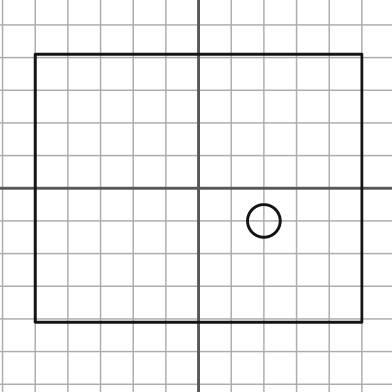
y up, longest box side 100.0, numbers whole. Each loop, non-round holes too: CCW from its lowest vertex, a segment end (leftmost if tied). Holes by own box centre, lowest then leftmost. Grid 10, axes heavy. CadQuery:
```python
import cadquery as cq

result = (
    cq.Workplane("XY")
    .moveTo(-50.0, -41.0)
    .lineTo(50.0, -41.0)
    .lineTo(50.0, 41.0)
    .lineTo(-50.0, 41.0)
    .close()
    .moveTo(20.0, -10.0)
    .circle(5.0)
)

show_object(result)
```